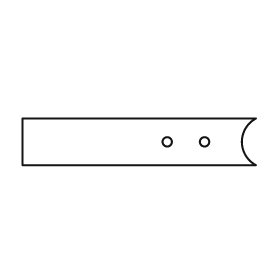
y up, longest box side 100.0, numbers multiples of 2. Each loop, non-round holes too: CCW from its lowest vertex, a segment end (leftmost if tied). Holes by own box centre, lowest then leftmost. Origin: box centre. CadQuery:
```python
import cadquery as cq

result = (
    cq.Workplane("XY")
    .moveTo(-50.0, -10.0)
    .lineTo(50.0, -10.0)
    .threePointArc((44.0, 0.0), (50.0, 10.0))
    .lineTo(-50.0, 10.0)
    .close()
    .moveTo(12.0, 0.0)
    .circle(2.0)
    .moveTo(28.0, 0.0)
    .circle(2.0)
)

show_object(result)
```